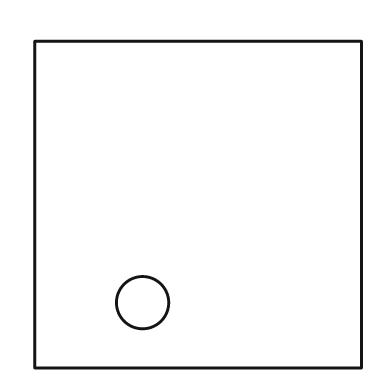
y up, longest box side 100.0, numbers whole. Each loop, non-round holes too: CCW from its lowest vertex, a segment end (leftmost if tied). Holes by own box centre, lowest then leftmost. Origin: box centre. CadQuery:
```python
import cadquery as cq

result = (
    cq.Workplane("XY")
    .moveTo(-50.0, -50.0)
    .lineTo(50.0, -50.0)
    .lineTo(50.0, 50.0)
    .lineTo(-50.0, 50.0)
    .close()
    .moveTo(-17.0, -30.0)
    .circle(8.0)
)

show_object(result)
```